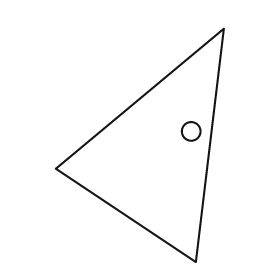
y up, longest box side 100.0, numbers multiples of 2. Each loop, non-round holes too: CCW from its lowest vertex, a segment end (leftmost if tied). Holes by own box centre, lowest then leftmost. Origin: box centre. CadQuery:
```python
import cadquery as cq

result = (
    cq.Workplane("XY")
    .moveTo(24.0, -50.0)
    .lineTo(36.0, 50.0)
    .lineTo(-36.0, -10.0)
    .close()
    .moveTo(22.0, 6.0)
    .circle(4.0)
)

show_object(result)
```